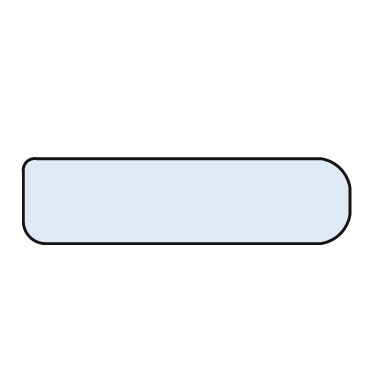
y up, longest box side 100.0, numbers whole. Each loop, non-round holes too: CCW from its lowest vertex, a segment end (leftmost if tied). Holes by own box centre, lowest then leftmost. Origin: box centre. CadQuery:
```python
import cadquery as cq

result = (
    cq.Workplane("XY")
    .moveTo(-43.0, -13.0)
    .lineTo(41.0, -13.0)
    .threePointArc((47.0, -10.0), (50.0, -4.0))
    .lineTo(50.0, 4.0)
    .threePointArc((47.0, 10.0), (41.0, 13.0))
    .lineTo(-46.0, 13.0)
    .threePointArc((-49.0, 12.0), (-50.0, 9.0))
    .lineTo(-50.0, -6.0)
    .threePointArc((-48.0, -11.0), (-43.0, -13.0))
    .close()
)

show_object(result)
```